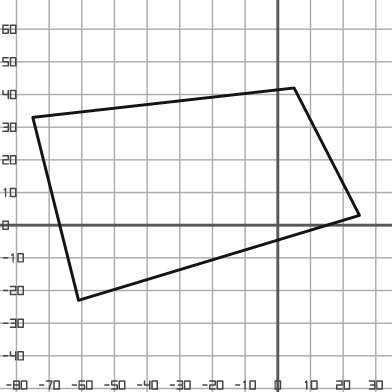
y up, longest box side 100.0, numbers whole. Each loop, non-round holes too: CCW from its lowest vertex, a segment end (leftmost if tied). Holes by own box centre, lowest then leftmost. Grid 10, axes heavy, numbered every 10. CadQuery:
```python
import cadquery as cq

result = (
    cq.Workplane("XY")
    .moveTo(-61.0, -23.0)
    .lineTo(25.0, 3.0)
    .lineTo(5.0, 42.0)
    .lineTo(-75.0, 33.0)
    .close()
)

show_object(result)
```